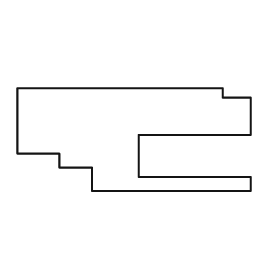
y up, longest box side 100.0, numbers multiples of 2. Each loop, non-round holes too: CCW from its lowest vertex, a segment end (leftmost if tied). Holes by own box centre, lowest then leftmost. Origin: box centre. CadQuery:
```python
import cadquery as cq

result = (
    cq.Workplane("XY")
    .moveTo(-18.0, -22.0)
    .lineTo(50.0, -22.0)
    .lineTo(50.0, -16.0)
    .lineTo(2.0, -16.0)
    .lineTo(2.0, 2.0)
    .lineTo(50.0, 2.0)
    .lineTo(50.0, 18.0)
    .lineTo(38.0, 18.0)
    .lineTo(38.0, 22.0)
    .lineTo(-50.0, 22.0)
    .lineTo(-50.0, -6.0)
    .lineTo(-32.0, -6.0)
    .lineTo(-32.0, -12.0)
    .lineTo(-18.0, -12.0)
    .close()
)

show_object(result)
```